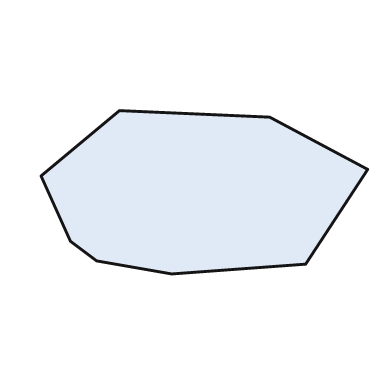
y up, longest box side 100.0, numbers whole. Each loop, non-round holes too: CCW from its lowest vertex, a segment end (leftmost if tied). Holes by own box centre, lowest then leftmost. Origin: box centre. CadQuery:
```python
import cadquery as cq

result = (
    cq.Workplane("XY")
    .moveTo(-10.0, -25.0)
    .lineTo(31.0, -22.0)
    .lineTo(50.0, 7.0)
    .lineTo(20.0, 23.0)
    .lineTo(-26.0, 25.0)
    .lineTo(-50.0, 5.0)
    .lineTo(-41.0, -15.0)
    .lineTo(-33.0, -21.0)
    .close()
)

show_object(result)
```